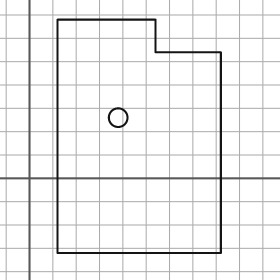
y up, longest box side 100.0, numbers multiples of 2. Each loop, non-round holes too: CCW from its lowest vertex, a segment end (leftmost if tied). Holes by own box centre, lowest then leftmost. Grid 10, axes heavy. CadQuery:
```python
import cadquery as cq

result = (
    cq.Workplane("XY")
    .moveTo(12.0, -32.0)
    .lineTo(82.0, -32.0)
    .lineTo(82.0, 54.0)
    .lineTo(54.0, 54.0)
    .lineTo(54.0, 68.0)
    .lineTo(12.0, 68.0)
    .close()
    .moveTo(38.0, 26.0)
    .circle(4.0)
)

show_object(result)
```